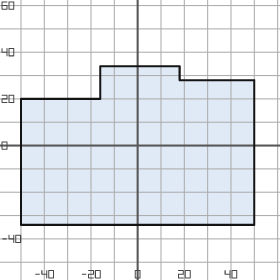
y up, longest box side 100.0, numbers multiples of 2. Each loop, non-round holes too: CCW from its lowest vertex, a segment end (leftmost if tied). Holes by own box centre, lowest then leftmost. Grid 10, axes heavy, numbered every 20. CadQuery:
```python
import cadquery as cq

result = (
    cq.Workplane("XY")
    .moveTo(-50.0, -34.0)
    .lineTo(50.0, -34.0)
    .lineTo(50.0, 28.0)
    .lineTo(18.0, 28.0)
    .lineTo(18.0, 34.0)
    .lineTo(-16.0, 34.0)
    .lineTo(-16.0, 20.0)
    .lineTo(-50.0, 20.0)
    .close()
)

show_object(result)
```